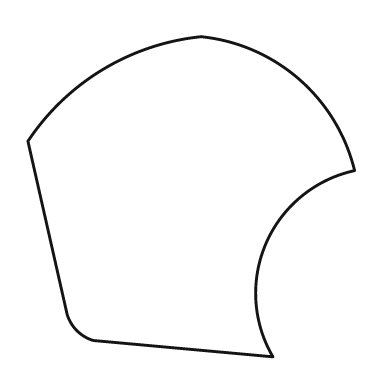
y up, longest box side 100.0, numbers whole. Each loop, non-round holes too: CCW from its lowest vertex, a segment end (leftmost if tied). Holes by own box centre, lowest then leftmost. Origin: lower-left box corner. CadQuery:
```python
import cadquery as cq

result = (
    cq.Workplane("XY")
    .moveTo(75.0, 0.0)
    .threePointArc((73.0, 35.0), (100.0, 57.0))
    .threePointArc((83.0, 85.0), (53.0, 98.0))
    .threePointArc((23.0, 88.0), (0.0, 66.0))
    .lineTo(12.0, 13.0)
    .threePointArc((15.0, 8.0), (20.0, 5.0))
    .close()
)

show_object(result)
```